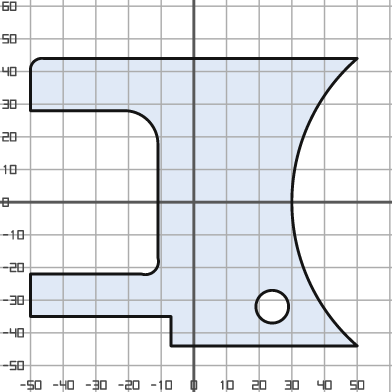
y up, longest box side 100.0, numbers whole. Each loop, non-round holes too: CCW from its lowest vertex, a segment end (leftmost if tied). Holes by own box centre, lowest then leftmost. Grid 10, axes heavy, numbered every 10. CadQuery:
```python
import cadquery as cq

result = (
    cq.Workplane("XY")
    .moveTo(-7.0, -44.0)
    .lineTo(50.0, -44.0)
    .threePointArc((30.0, 0.0), (50.0, 44.0))
    .lineTo(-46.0, 44.0)
    .threePointArc((-49.0, 43.0), (-50.0, 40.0))
    .lineTo(-50.0, 28.0)
    .lineTo(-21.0, 28.0)
    .threePointArc((-14.0, 25.0), (-11.0, 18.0))
    .lineTo(-11.0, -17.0)
    .threePointArc((-12.0, -21.0), (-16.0, -22.0))
    .lineTo(-50.0, -22.0)
    .lineTo(-50.0, -35.0)
    .lineTo(-7.0, -35.0)
    .close()
    .moveTo(24.0, -32.0)
    .circle(5.0)
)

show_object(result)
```